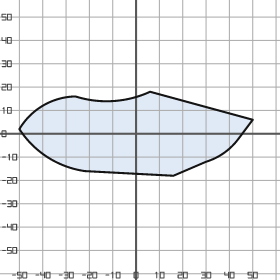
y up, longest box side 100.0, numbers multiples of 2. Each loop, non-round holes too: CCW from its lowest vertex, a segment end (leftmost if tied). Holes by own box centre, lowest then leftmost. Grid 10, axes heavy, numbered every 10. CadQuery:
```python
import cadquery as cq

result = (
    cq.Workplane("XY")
    .moveTo(16.0, -18.0)
    .lineTo(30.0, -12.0)
    .threePointArc((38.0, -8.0), (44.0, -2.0))
    .lineTo(50.0, 6.0)
    .lineTo(6.0, 18.0)
    .threePointArc((-10.0, 14.0), (-26.0, 16.0))
    .threePointArc((-40.0, 12.0), (-50.0, 2.0))
    .threePointArc((-38.0, -10.0), (-22.0, -16.0))
    .close()
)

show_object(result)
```